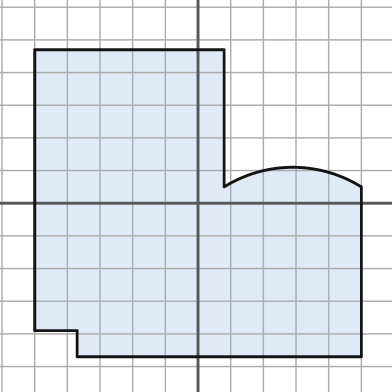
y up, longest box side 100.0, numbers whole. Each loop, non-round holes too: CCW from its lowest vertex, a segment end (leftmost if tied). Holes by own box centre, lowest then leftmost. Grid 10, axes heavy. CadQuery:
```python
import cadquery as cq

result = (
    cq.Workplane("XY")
    .moveTo(-37.0, -47.0)
    .lineTo(50.0, -47.0)
    .lineTo(50.0, 5.0)
    .threePointArc((29.0, 11.0), (8.0, 5.0))
    .lineTo(8.0, 47.0)
    .lineTo(-50.0, 47.0)
    .lineTo(-50.0, -39.0)
    .lineTo(-37.0, -39.0)
    .close()
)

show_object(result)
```